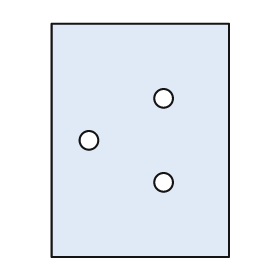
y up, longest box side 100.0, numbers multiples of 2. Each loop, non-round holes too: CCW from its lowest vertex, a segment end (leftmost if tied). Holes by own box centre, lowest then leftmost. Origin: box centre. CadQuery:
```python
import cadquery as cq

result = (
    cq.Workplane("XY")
    .moveTo(-38.0, -50.0)
    .lineTo(38.0, -50.0)
    .lineTo(38.0, 50.0)
    .lineTo(-38.0, 50.0)
    .close()
    .moveTo(10.0, -18.0)
    .circle(4.0)
    .moveTo(-22.0, 0.0)
    .circle(4.0)
    .moveTo(10.0, 18.0)
    .circle(4.0)
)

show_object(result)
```